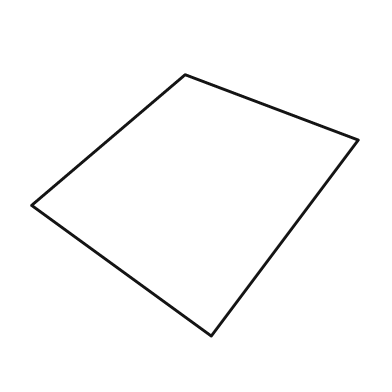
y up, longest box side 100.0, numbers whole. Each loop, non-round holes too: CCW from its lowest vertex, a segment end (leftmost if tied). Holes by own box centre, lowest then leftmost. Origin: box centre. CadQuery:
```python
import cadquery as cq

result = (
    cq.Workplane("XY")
    .moveTo(5.0, -40.0)
    .lineTo(50.0, 20.0)
    .lineTo(-3.0, 40.0)
    .lineTo(-50.0, 0.0)
    .close()
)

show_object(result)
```